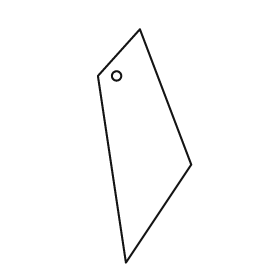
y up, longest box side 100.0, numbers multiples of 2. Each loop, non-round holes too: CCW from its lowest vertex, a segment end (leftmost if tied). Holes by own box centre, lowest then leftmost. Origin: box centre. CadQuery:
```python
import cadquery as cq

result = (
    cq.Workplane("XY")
    .moveTo(-8.0, -50.0)
    .lineTo(20.0, -8.0)
    .lineTo(-2.0, 50.0)
    .lineTo(-20.0, 30.0)
    .close()
    .moveTo(-12.0, 30.0)
    .circle(2.0)
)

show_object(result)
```